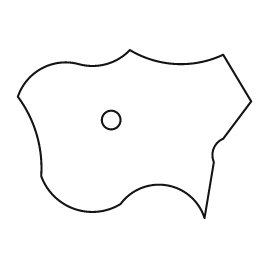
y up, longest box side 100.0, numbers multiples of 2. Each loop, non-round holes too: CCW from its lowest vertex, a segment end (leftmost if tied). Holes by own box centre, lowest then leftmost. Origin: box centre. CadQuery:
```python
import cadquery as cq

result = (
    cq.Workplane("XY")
    .moveTo(30.0, -36.0)
    .lineTo(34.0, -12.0)
    .threePointArc((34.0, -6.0), (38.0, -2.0))
    .lineTo(50.0, 14.0)
    .lineTo(38.0, 34.0)
    .threePointArc((18.0, 30.0), (-2.0, 36.0))
    .threePointArc((-12.0, 30.0), (-24.0, 30.0))
    .threePointArc((-40.0, 28.0), (-50.0, 16.0))
    .threePointArc((-42.0, 0.0), (-40.0, -18.0))
    .threePointArc((-26.0, -32.0), (-6.0, -30.0))
    .threePointArc((14.0, -22.0), (30.0, -36.0))
    .close()
    .moveTo(-10.0, 6.0)
    .circle(4.0)
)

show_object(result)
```